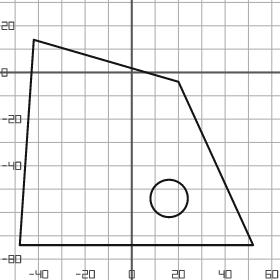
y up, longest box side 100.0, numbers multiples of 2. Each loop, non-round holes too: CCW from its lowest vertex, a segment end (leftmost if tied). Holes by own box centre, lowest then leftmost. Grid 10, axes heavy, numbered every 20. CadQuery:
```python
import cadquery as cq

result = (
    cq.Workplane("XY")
    .moveTo(-48.0, -74.0)
    .lineTo(52.0, -74.0)
    .lineTo(20.0, -4.0)
    .lineTo(-42.0, 14.0)
    .close()
    .moveTo(16.0, -54.0)
    .circle(8.0)
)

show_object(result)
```